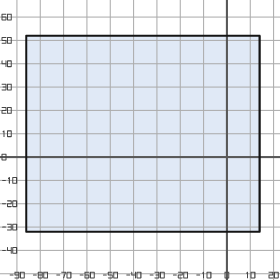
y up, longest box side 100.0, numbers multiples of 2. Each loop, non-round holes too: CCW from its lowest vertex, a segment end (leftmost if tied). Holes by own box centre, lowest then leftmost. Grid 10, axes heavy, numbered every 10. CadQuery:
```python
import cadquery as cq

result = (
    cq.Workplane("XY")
    .moveTo(-86.0, -32.0)
    .lineTo(14.0, -32.0)
    .lineTo(14.0, 52.0)
    .lineTo(-86.0, 52.0)
    .close()
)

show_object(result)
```